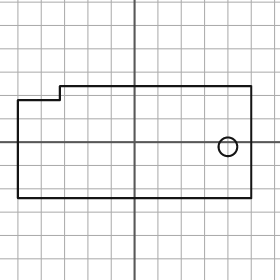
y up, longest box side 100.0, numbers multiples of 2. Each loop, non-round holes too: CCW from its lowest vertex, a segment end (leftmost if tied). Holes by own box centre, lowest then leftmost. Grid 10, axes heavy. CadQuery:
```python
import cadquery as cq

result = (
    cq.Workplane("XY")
    .moveTo(-50.0, -24.0)
    .lineTo(50.0, -24.0)
    .lineTo(50.0, 24.0)
    .lineTo(-32.0, 24.0)
    .lineTo(-32.0, 18.0)
    .lineTo(-50.0, 18.0)
    .close()
    .moveTo(40.0, -2.0)
    .circle(4.0)
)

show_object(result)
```